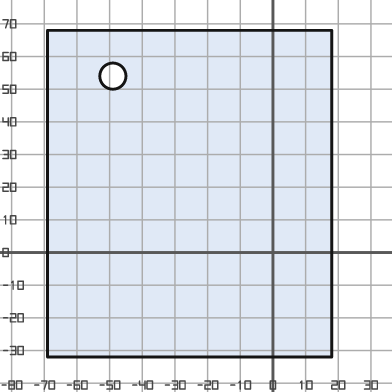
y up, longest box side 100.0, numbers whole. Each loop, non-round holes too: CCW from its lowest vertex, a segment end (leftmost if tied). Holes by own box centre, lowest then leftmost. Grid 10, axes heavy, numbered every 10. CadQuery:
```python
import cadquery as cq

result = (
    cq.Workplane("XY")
    .moveTo(-69.0, -32.0)
    .lineTo(18.0, -32.0)
    .lineTo(18.0, 68.0)
    .lineTo(-69.0, 68.0)
    .close()
    .moveTo(-49.0, 54.0)
    .circle(4.0)
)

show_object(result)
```